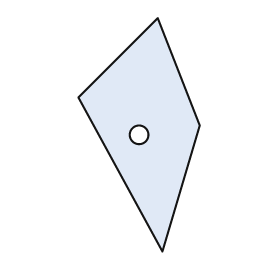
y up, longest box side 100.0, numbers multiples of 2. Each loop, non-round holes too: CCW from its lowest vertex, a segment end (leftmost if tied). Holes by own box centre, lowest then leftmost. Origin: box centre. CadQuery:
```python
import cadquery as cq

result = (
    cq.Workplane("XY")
    .moveTo(10.0, -50.0)
    .lineTo(26.0, 4.0)
    .lineTo(8.0, 50.0)
    .lineTo(-26.0, 16.0)
    .close()
    .moveTo(0.0, 0.0)
    .circle(4.0)
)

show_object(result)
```